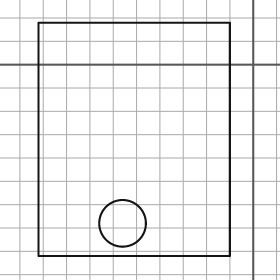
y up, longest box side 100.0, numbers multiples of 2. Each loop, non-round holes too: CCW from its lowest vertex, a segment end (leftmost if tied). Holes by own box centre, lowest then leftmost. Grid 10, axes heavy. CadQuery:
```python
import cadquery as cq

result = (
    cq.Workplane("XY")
    .moveTo(-92.0, -82.0)
    .lineTo(-10.0, -82.0)
    .lineTo(-10.0, 18.0)
    .lineTo(-92.0, 18.0)
    .close()
    .moveTo(-56.0, -68.0)
    .circle(10.0)
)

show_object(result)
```